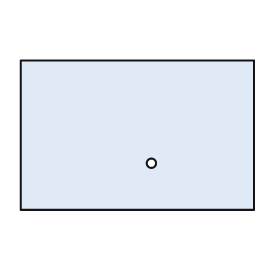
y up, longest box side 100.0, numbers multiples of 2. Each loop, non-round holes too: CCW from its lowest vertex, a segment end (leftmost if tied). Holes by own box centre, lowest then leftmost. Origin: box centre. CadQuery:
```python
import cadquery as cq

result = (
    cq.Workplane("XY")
    .moveTo(-50.0, -32.0)
    .lineTo(50.0, -32.0)
    .lineTo(50.0, 32.0)
    .lineTo(-50.0, 32.0)
    .close()
    .moveTo(6.0, -12.0)
    .circle(2.0)
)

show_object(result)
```